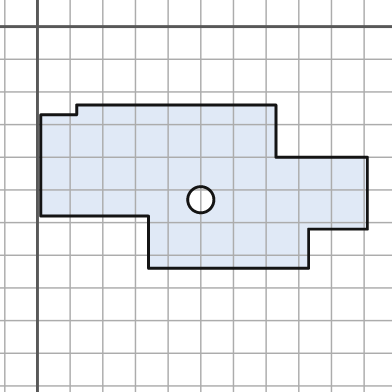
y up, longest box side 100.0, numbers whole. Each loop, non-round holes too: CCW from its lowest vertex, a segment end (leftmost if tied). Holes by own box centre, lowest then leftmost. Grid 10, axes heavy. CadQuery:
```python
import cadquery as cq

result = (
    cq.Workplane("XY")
    .moveTo(34.0, -74.0)
    .lineTo(83.0, -74.0)
    .lineTo(83.0, -62.0)
    .lineTo(101.0, -62.0)
    .lineTo(101.0, -40.0)
    .lineTo(73.0, -40.0)
    .lineTo(73.0, -24.0)
    .lineTo(12.0, -24.0)
    .lineTo(12.0, -27.0)
    .lineTo(1.0, -27.0)
    .lineTo(1.0, -58.0)
    .lineTo(34.0, -58.0)
    .close()
    .moveTo(50.0, -53.0)
    .circle(4.0)
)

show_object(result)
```